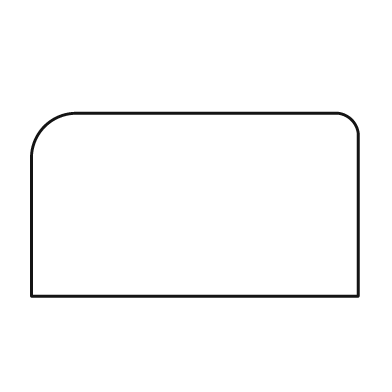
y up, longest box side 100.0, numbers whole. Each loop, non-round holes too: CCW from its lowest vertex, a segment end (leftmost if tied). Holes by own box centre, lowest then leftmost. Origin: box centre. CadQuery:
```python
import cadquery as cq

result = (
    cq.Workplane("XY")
    .moveTo(-50.0, -28.0)
    .lineTo(50.0, -28.0)
    .lineTo(50.0, 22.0)
    .threePointArc((48.0, 26.0), (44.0, 28.0))
    .lineTo(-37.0, 28.0)
    .threePointArc((-46.0, 24.0), (-50.0, 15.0))
    .close()
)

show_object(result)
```